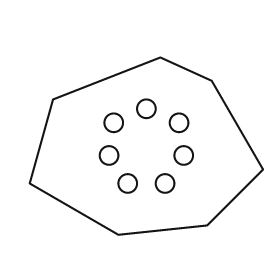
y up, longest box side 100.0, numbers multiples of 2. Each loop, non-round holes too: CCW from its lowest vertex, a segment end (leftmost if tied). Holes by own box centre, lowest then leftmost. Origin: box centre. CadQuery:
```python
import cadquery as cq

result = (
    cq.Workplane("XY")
    .moveTo(-12.0, -38.0)
    .lineTo(26.0, -34.0)
    .lineTo(50.0, -10.0)
    .lineTo(28.0, 28.0)
    .lineTo(6.0, 38.0)
    .lineTo(-40.0, 20.0)
    .lineTo(-50.0, -16.0)
    .close()
    .moveTo(-8.0, -16.0)
    .circle(4.0)
    .moveTo(8.0, -16.0)
    .circle(4.0)
    .moveTo(-16.0, -4.0)
    .circle(4.0)
    .moveTo(16.0, -4.0)
    .circle(4.0)
    .moveTo(-14.0, 10.0)
    .circle(4.0)
    .moveTo(14.0, 10.0)
    .circle(4.0)
    .moveTo(0.0, 16.0)
    .circle(4.0)
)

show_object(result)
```